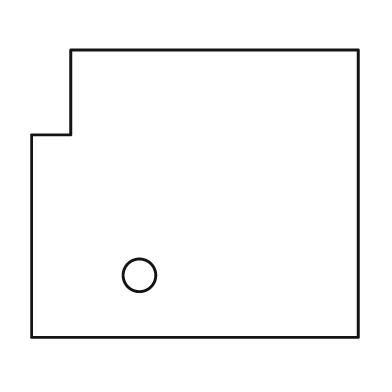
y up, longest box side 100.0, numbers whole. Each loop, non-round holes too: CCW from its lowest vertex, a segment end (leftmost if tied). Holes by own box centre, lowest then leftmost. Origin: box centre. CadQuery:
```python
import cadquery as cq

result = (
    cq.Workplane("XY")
    .moveTo(-50.0, -44.0)
    .lineTo(50.0, -44.0)
    .lineTo(50.0, 44.0)
    .lineTo(-38.0, 44.0)
    .lineTo(-38.0, 18.0)
    .lineTo(-50.0, 18.0)
    .close()
    .moveTo(-17.0, -25.0)
    .circle(5.0)
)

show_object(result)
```